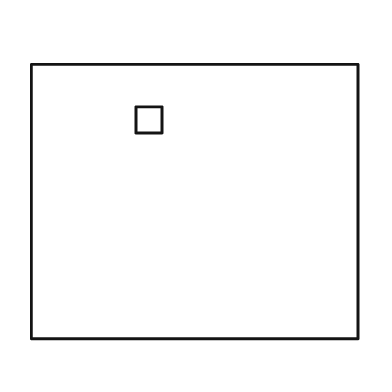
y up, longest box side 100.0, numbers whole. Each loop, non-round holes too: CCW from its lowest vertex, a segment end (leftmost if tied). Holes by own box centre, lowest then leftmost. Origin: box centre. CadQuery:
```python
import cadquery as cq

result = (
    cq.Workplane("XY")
    .moveTo(-50.0, -42.0)
    .lineTo(50.0, -42.0)
    .lineTo(50.0, 42.0)
    .lineTo(-50.0, 42.0)
    .close()
    .moveTo(-18.0, 21.0)
    .lineTo(-10.0, 21.0)
    .lineTo(-10.0, 29.0)
    .lineTo(-18.0, 29.0)
    .close()
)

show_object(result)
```